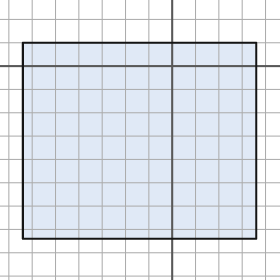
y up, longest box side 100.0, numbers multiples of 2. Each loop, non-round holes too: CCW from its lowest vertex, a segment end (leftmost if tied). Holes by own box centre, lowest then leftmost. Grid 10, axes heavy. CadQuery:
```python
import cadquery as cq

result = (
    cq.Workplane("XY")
    .moveTo(-64.0, -74.0)
    .lineTo(36.0, -74.0)
    .lineTo(36.0, 10.0)
    .lineTo(-64.0, 10.0)
    .close()
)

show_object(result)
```